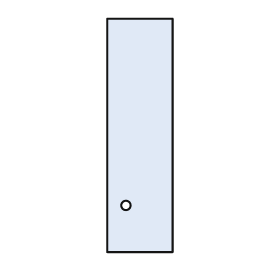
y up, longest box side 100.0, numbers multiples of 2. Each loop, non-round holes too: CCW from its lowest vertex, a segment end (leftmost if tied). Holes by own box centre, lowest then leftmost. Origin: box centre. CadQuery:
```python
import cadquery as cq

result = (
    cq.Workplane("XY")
    .moveTo(-14.0, -50.0)
    .lineTo(14.0, -50.0)
    .lineTo(14.0, 50.0)
    .lineTo(-14.0, 50.0)
    .close()
    .moveTo(-6.0, -30.0)
    .circle(2.0)
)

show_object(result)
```